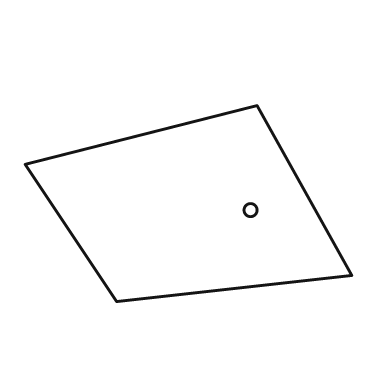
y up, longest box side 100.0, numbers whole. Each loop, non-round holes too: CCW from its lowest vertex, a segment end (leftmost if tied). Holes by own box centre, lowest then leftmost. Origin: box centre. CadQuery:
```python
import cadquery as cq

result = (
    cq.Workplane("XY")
    .moveTo(-22.0, -30.0)
    .lineTo(50.0, -22.0)
    .lineTo(21.0, 30.0)
    .lineTo(-50.0, 12.0)
    .close()
    .moveTo(19.0, -2.0)
    .circle(2.0)
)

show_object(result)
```